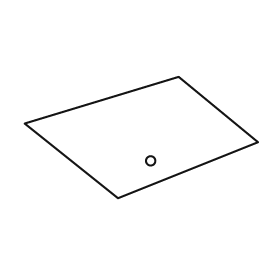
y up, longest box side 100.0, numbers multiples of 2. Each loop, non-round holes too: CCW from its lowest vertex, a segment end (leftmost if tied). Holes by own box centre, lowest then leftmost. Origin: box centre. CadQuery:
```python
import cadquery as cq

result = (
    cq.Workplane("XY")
    .moveTo(-10.0, -26.0)
    .lineTo(50.0, -2.0)
    .lineTo(16.0, 26.0)
    .lineTo(-50.0, 6.0)
    .close()
    .moveTo(4.0, -10.0)
    .circle(2.0)
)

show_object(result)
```